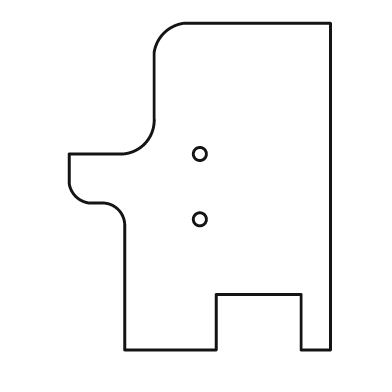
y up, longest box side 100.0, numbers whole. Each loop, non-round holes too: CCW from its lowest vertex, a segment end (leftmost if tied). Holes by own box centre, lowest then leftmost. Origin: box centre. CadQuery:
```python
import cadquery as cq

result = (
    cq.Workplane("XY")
    .moveTo(-23.0, -50.0)
    .lineTo(5.0, -50.0)
    .lineTo(5.0, -33.0)
    .lineTo(31.0, -33.0)
    .lineTo(31.0, -50.0)
    .lineTo(40.0, -50.0)
    .lineTo(40.0, 50.0)
    .lineTo(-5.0, 50.0)
    .threePointArc((-11.0, 47.0), (-14.0, 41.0))
    .lineTo(-14.0, 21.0)
    .threePointArc((-17.0, 13.0), (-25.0, 10.0))
    .lineTo(-40.0, 10.0)
    .lineTo(-40.0, 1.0)
    .threePointArc((-38.0, -3.0), (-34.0, -5.0))
    .lineTo(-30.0, -5.0)
    .threePointArc((-25.0, -7.0), (-23.0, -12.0))
    .close()
    .moveTo(0.0, -10.0)
    .circle(2.0)
    .moveTo(0.0, 10.0)
    .circle(2.0)
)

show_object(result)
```